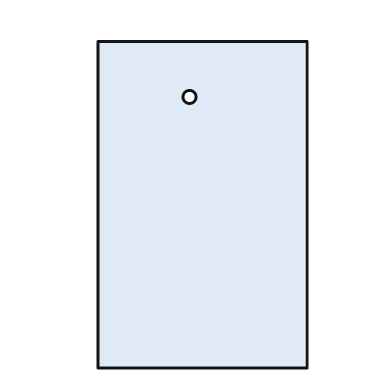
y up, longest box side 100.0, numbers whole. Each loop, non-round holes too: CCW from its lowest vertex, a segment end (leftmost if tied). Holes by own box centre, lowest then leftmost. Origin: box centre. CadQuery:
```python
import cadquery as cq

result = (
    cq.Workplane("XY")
    .moveTo(-32.0, -50.0)
    .lineTo(32.0, -50.0)
    .lineTo(32.0, 50.0)
    .lineTo(-32.0, 50.0)
    .close()
    .moveTo(-4.0, 33.0)
    .circle(2.0)
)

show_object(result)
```